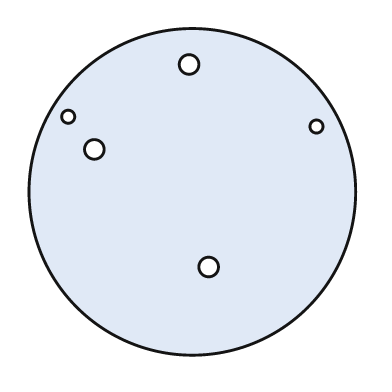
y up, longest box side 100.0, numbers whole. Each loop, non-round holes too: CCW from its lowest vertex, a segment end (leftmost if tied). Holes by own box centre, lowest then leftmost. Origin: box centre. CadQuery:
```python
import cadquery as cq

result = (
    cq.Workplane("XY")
    .moveTo(0.0, 0.0)
    .circle(50.0)
    .moveTo(5.0, -23.0)
    .circle(3.0)
    .moveTo(-30.0, 13.0)
    .circle(3.0)
    .moveTo(38.0, 20.0)
    .circle(2.0)
    .moveTo(-38.0, 23.0)
    .circle(2.0)
    .moveTo(-1.0, 39.0)
    .circle(3.0)
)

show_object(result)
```